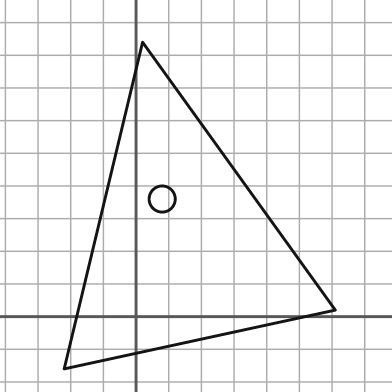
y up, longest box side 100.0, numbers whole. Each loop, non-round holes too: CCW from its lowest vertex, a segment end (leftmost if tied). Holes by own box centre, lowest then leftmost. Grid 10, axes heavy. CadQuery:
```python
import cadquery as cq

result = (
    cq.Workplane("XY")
    .moveTo(-22.0, -16.0)
    .lineTo(61.0, 2.0)
    .lineTo(2.0, 84.0)
    .close()
    .moveTo(8.0, 36.0)
    .circle(4.0)
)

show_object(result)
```